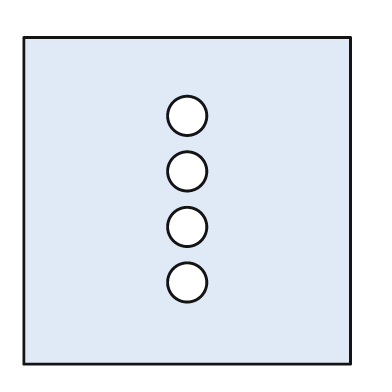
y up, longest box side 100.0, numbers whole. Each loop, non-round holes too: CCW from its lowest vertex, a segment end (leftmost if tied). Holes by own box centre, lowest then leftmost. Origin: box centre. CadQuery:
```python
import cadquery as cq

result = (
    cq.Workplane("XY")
    .moveTo(-50.0, -50.0)
    .lineTo(50.0, -50.0)
    .lineTo(50.0, 50.0)
    .lineTo(-50.0, 50.0)
    .close()
    .moveTo(0.0, -25.0)
    .circle(6.0)
    .moveTo(0.0, -8.0)
    .circle(6.0)
    .moveTo(0.0, 9.0)
    .circle(6.0)
    .moveTo(0.0, 26.0)
    .circle(6.0)
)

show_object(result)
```